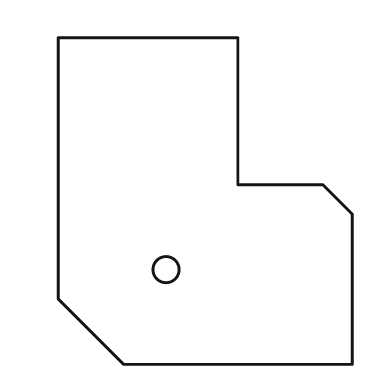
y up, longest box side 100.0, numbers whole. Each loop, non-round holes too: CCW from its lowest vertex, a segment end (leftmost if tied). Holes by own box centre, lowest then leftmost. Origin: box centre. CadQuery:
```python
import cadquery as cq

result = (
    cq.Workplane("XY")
    .moveTo(-25.0, -50.0)
    .lineTo(45.0, -50.0)
    .lineTo(45.0, -4.0)
    .lineTo(36.0, 5.0)
    .lineTo(10.0, 5.0)
    .lineTo(10.0, 50.0)
    .lineTo(-45.0, 50.0)
    .lineTo(-45.0, -30.0)
    .close()
    .moveTo(-12.0, -21.0)
    .circle(4.0)
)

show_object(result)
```